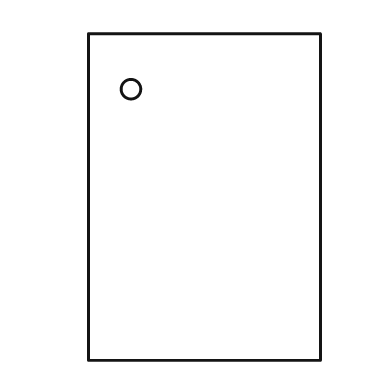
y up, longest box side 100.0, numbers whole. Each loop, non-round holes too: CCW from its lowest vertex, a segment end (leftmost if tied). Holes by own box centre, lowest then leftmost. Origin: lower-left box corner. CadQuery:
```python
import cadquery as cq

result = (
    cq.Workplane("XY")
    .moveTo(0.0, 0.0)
    .lineTo(71.0, 0.0)
    .lineTo(71.0, 100.0)
    .lineTo(0.0, 100.0)
    .close()
    .moveTo(13.0, 83.0)
    .circle(3.0)
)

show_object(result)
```